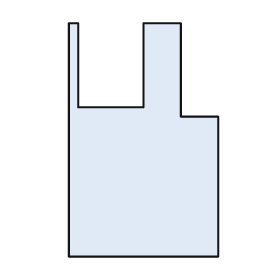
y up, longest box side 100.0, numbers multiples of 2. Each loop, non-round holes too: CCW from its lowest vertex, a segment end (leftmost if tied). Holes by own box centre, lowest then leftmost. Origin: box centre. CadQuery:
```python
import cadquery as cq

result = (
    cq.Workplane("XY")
    .moveTo(-32.0, -50.0)
    .lineTo(32.0, -50.0)
    .lineTo(32.0, 10.0)
    .lineTo(16.0, 10.0)
    .lineTo(16.0, 50.0)
    .lineTo(0.0, 50.0)
    .lineTo(0.0, 14.0)
    .lineTo(-28.0, 14.0)
    .lineTo(-28.0, 50.0)
    .lineTo(-32.0, 50.0)
    .close()
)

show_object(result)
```